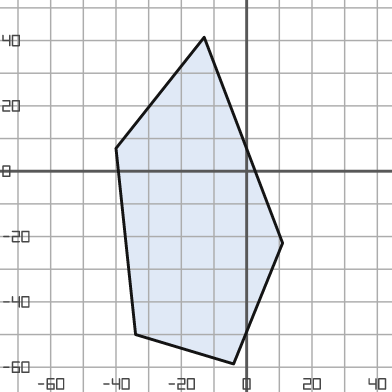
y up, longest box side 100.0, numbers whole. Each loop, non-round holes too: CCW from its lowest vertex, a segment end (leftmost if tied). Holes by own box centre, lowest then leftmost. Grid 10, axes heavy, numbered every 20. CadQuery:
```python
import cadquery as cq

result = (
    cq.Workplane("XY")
    .moveTo(-4.0, -59.0)
    .lineTo(11.0, -22.0)
    .lineTo(-13.0, 41.0)
    .lineTo(-40.0, 7.0)
    .lineTo(-34.0, -50.0)
    .close()
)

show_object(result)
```